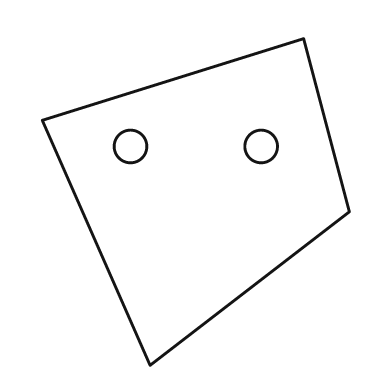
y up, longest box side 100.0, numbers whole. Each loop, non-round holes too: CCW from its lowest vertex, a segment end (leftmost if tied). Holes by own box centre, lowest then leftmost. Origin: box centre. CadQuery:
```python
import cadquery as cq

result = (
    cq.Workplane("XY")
    .moveTo(-14.0, -50.0)
    .lineTo(47.0, -3.0)
    .lineTo(33.0, 50.0)
    .lineTo(-47.0, 25.0)
    .close()
    .moveTo(-20.0, 17.0)
    .circle(5.0)
    .moveTo(20.0, 17.0)
    .circle(5.0)
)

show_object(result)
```